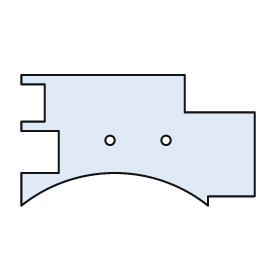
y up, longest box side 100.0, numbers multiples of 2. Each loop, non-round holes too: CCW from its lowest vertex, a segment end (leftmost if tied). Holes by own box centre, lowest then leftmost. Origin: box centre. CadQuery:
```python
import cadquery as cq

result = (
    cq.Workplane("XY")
    .moveTo(-50.0, -28.0)
    .threePointArc((-10.0, -14.0), (30.0, -28.0))
    .lineTo(30.0, -24.0)
    .lineTo(50.0, -24.0)
    .lineTo(50.0, 12.0)
    .lineTo(20.0, 12.0)
    .lineTo(20.0, 28.0)
    .lineTo(-50.0, 28.0)
    .lineTo(-50.0, 24.0)
    .lineTo(-40.0, 24.0)
    .lineTo(-40.0, 8.0)
    .lineTo(-50.0, 8.0)
    .lineTo(-50.0, 4.0)
    .lineTo(-34.0, 4.0)
    .lineTo(-34.0, -14.0)
    .lineTo(-50.0, -14.0)
    .close()
    .moveTo(-12.0, 0.0)
    .circle(2.0)
    .moveTo(12.0, 0.0)
    .circle(2.0)
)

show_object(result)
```